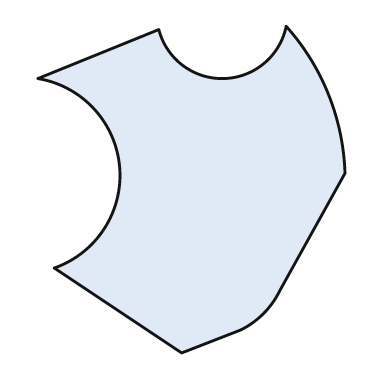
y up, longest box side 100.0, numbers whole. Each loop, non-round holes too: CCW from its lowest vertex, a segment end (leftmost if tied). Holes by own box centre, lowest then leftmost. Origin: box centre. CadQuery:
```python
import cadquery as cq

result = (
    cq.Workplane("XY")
    .moveTo(-3.0, -50.0)
    .lineTo(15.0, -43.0)
    .threePointArc((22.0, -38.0), (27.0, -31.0))
    .lineTo(47.0, 5.0)
    .threePointArc((42.0, 29.0), (29.0, 50.0))
    .threePointArc((10.0, 34.0), (-10.0, 49.0))
    .lineTo(-47.0, 34.0)
    .threePointArc((-22.0, 7.0), (-42.0, -24.0))
    .close()
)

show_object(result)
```